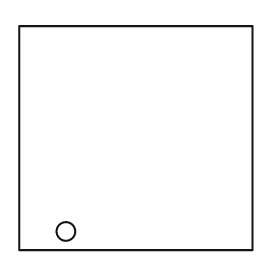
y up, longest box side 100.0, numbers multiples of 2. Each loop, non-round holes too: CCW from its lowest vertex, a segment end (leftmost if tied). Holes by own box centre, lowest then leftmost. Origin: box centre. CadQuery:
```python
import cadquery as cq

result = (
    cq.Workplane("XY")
    .moveTo(-50.0, -48.0)
    .lineTo(50.0, -48.0)
    .lineTo(50.0, 48.0)
    .lineTo(-50.0, 48.0)
    .close()
    .moveTo(-30.0, -40.0)
    .circle(4.0)
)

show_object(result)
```